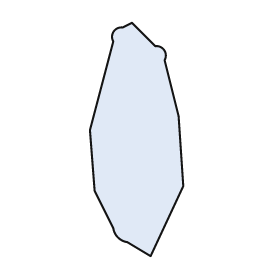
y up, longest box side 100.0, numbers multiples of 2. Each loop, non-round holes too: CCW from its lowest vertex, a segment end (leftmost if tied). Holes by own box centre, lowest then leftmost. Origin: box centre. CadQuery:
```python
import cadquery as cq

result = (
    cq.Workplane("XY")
    .moveTo(6.0, -50.0)
    .lineTo(20.0, -20.0)
    .lineTo(18.0, 10.0)
    .lineTo(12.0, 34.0)
    .threePointArc((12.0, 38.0), (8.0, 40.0))
    .lineTo(-2.0, 50.0)
    .lineTo(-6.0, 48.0)
    .threePointArc((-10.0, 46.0), (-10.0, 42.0))
    .lineTo(-20.0, 4.0)
    .lineTo(-18.0, -22.0)
    .lineTo(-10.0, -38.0)
    .threePointArc((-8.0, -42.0), (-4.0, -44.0))
    .close()
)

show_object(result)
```